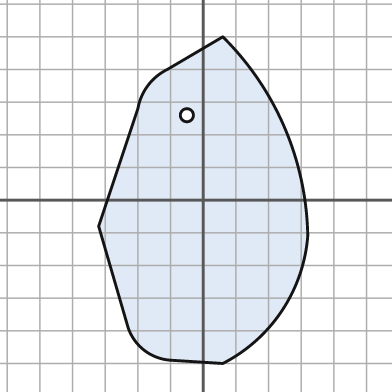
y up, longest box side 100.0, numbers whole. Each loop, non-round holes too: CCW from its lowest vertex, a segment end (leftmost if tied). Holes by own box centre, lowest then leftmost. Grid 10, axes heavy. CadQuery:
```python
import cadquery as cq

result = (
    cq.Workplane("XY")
    .moveTo(6.0, -50.0)
    .threePointArc((24.0, -34.0), (32.0, -11.0))
    .threePointArc((25.0, 22.0), (6.0, 50.0))
    .lineTo(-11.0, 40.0)
    .threePointArc((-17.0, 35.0), (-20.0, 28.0))
    .lineTo(-32.0, -8.0)
    .lineTo(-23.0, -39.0)
    .threePointArc((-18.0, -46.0), (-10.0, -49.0))
    .close()
    .moveTo(-5.0, 26.0)
    .circle(2.0)
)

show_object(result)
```